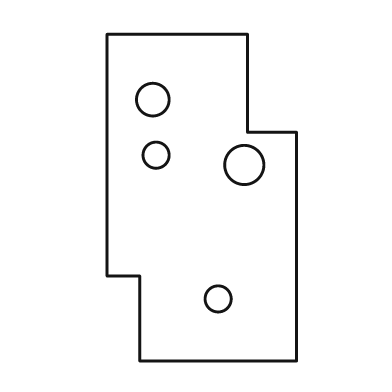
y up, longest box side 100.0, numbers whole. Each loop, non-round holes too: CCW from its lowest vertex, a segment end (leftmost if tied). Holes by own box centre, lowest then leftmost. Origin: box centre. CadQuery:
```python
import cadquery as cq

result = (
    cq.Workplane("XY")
    .moveTo(-19.0, -50.0)
    .lineTo(29.0, -50.0)
    .lineTo(29.0, 20.0)
    .lineTo(14.0, 20.0)
    .lineTo(14.0, 50.0)
    .lineTo(-29.0, 50.0)
    .lineTo(-29.0, -24.0)
    .lineTo(-19.0, -24.0)
    .close()
    .moveTo(5.0, -31.0)
    .circle(4.0)
    .moveTo(13.0, 10.0)
    .circle(6.0)
    .moveTo(-14.0, 13.0)
    .circle(4.0)
    .moveTo(-15.0, 30.0)
    .circle(5.0)
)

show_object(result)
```